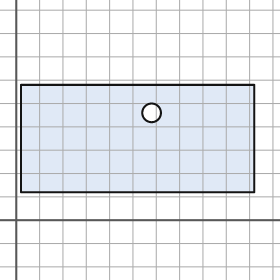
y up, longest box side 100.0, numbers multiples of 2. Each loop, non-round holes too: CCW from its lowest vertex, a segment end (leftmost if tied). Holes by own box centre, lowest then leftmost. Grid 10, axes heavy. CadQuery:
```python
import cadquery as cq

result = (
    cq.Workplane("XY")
    .moveTo(2.0, 12.0)
    .lineTo(102.0, 12.0)
    .lineTo(102.0, 58.0)
    .lineTo(2.0, 58.0)
    .close()
    .moveTo(58.0, 46.0)
    .circle(4.0)
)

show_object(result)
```